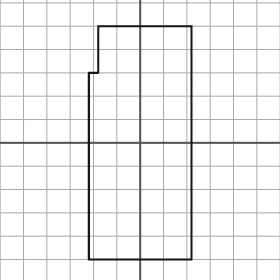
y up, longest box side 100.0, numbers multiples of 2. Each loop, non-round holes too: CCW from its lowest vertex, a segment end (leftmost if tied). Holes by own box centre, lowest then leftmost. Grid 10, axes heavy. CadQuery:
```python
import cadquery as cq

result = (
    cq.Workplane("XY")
    .moveTo(-22.0, -50.0)
    .lineTo(22.0, -50.0)
    .lineTo(22.0, 50.0)
    .lineTo(-18.0, 50.0)
    .lineTo(-18.0, 30.0)
    .lineTo(-22.0, 30.0)
    .close()
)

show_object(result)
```